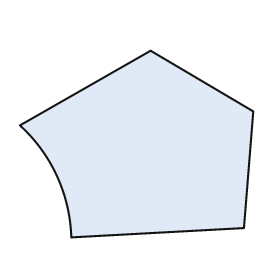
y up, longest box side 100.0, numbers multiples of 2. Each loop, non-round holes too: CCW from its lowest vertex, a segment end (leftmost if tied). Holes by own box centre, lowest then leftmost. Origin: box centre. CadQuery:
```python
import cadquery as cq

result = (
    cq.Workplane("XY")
    .moveTo(-28.0, -40.0)
    .lineTo(46.0, -36.0)
    .lineTo(50.0, 14.0)
    .lineTo(6.0, 40.0)
    .lineTo(-50.0, 8.0)
    .threePointArc((-34.0, -14.0), (-28.0, -40.0))
    .close()
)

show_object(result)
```